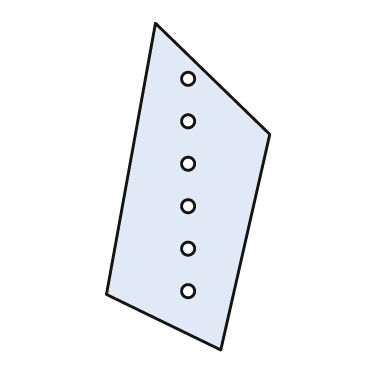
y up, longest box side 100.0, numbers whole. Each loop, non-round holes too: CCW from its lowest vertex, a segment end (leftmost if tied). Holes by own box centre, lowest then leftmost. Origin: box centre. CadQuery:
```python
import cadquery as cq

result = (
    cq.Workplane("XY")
    .moveTo(10.0, -50.0)
    .lineTo(25.0, 16.0)
    .lineTo(-10.0, 50.0)
    .lineTo(-25.0, -33.0)
    .close()
    .moveTo(0.0, -32.0)
    .circle(2.0)
    .moveTo(0.0, -19.0)
    .circle(2.0)
    .moveTo(0.0, -6.0)
    .circle(2.0)
    .moveTo(0.0, 7.0)
    .circle(2.0)
    .moveTo(0.0, 20.0)
    .circle(2.0)
    .moveTo(0.0, 33.0)
    .circle(2.0)
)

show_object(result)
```